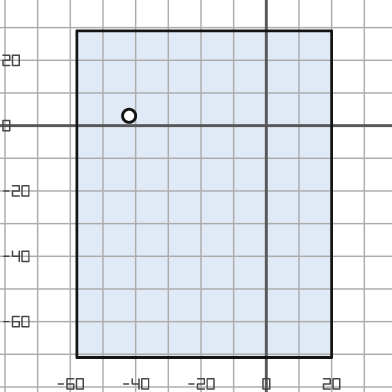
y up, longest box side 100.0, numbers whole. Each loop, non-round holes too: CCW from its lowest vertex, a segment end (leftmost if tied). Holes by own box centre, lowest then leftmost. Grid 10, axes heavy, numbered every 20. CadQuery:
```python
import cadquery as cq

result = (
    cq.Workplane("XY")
    .moveTo(-58.0, -71.0)
    .lineTo(20.0, -71.0)
    .lineTo(20.0, 29.0)
    .lineTo(-58.0, 29.0)
    .close()
    .moveTo(-42.0, 3.0)
    .circle(2.0)
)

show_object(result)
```